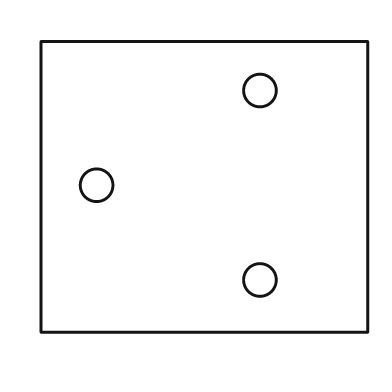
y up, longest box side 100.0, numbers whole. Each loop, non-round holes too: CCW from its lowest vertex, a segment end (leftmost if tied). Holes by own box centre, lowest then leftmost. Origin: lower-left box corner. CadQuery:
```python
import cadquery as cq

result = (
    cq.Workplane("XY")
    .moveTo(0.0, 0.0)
    .lineTo(100.0, 0.0)
    .lineTo(100.0, 89.0)
    .lineTo(0.0, 89.0)
    .close()
    .moveTo(67.0, 16.0)
    .circle(5.0)
    .moveTo(17.0, 45.0)
    .circle(5.0)
    .moveTo(67.0, 74.0)
    .circle(5.0)
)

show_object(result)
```